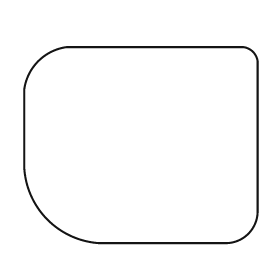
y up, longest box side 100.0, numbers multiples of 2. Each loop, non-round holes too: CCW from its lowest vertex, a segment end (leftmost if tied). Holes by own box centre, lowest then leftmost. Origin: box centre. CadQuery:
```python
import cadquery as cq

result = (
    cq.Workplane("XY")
    .moveTo(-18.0, -42.0)
    .lineTo(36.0, -42.0)
    .threePointArc((46.0, -38.0), (50.0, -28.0))
    .lineTo(50.0, 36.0)
    .threePointArc((48.0, 40.0), (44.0, 42.0))
    .lineTo(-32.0, 42.0)
    .threePointArc((-44.0, 36.0), (-50.0, 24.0))
    .lineTo(-50.0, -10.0)
    .threePointArc((-40.0, -32.0), (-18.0, -42.0))
    .close()
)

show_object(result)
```